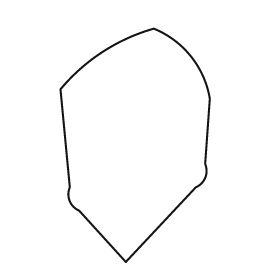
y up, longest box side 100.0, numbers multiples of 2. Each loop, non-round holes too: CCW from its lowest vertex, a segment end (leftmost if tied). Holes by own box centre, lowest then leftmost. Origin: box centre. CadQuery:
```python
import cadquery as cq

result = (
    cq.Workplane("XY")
    .moveTo(-4.0, -50.0)
    .lineTo(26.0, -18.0)
    .threePointArc((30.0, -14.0), (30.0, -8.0))
    .lineTo(32.0, 20.0)
    .threePointArc((24.0, 38.0), (8.0, 50.0))
    .threePointArc((-14.0, 40.0), (-32.0, 24.0))
    .lineTo(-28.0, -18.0)
    .threePointArc((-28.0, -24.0), (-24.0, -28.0))
    .close()
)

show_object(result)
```